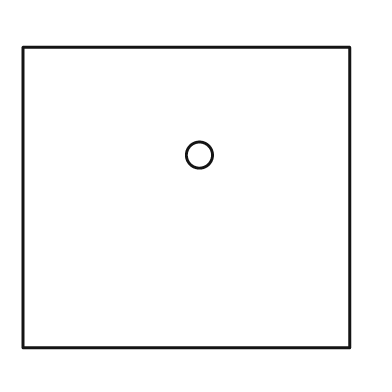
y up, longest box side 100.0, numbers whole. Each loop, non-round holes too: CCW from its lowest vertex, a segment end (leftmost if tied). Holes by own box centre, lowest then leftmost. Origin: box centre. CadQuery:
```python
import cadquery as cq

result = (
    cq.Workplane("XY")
    .moveTo(-50.0, -46.0)
    .lineTo(50.0, -46.0)
    .lineTo(50.0, 46.0)
    .lineTo(-50.0, 46.0)
    .close()
    .moveTo(4.0, 13.0)
    .circle(4.0)
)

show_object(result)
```